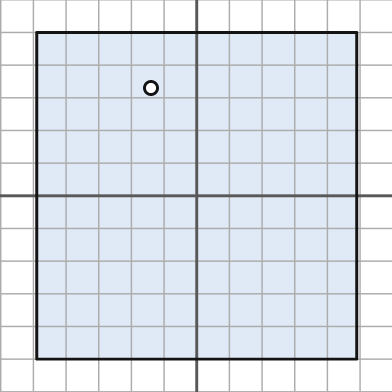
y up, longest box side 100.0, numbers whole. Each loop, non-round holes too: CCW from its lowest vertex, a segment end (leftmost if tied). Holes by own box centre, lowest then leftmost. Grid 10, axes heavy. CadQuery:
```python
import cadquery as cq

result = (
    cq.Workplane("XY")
    .moveTo(-49.0, -50.0)
    .lineTo(49.0, -50.0)
    .lineTo(49.0, 50.0)
    .lineTo(-49.0, 50.0)
    .close()
    .moveTo(-14.0, 33.0)
    .circle(2.0)
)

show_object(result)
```